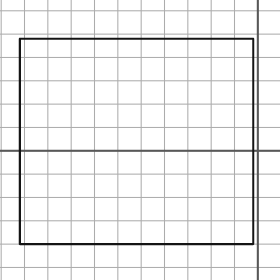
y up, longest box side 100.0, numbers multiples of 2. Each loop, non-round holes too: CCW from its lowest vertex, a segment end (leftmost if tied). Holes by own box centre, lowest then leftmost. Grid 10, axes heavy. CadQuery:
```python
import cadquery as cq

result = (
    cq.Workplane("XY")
    .moveTo(-102.0, -40.0)
    .lineTo(-2.0, -40.0)
    .lineTo(-2.0, 48.0)
    .lineTo(-102.0, 48.0)
    .close()
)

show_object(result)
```